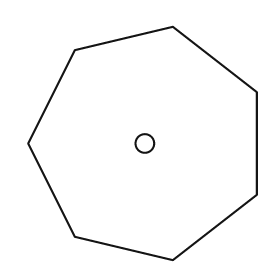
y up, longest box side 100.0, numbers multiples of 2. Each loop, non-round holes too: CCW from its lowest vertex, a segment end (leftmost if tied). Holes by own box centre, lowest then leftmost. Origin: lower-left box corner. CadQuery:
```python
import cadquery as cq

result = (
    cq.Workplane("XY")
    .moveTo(62.0, 0.0)
    .lineTo(98.0, 28.0)
    .lineTo(98.0, 72.0)
    .lineTo(62.0, 100.0)
    .lineTo(20.0, 90.0)
    .lineTo(0.0, 50.0)
    .lineTo(20.0, 10.0)
    .close()
    .moveTo(50.0, 50.0)
    .circle(4.0)
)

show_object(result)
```